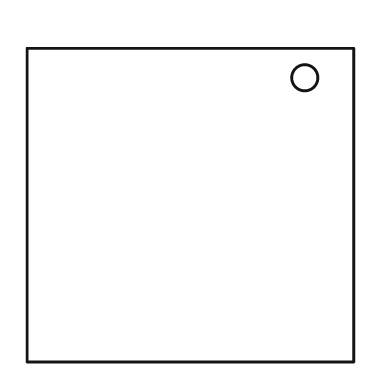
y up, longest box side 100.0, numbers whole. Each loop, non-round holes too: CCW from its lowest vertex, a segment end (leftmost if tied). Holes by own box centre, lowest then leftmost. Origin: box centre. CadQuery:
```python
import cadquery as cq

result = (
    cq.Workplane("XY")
    .moveTo(-50.0, -48.0)
    .lineTo(50.0, -48.0)
    .lineTo(50.0, 48.0)
    .lineTo(-50.0, 48.0)
    .close()
    .moveTo(35.0, 39.0)
    .circle(4.0)
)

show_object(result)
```